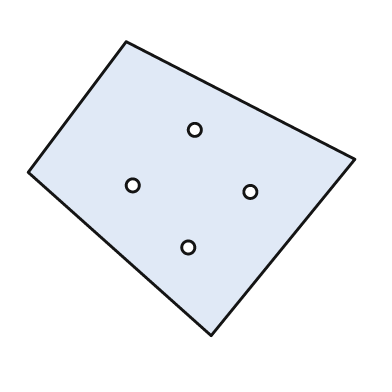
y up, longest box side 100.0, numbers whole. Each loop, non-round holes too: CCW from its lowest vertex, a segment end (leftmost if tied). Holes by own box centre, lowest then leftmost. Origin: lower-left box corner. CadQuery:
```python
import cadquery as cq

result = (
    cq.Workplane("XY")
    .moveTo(56.0, 0.0)
    .lineTo(100.0, 54.0)
    .lineTo(30.0, 90.0)
    .lineTo(0.0, 50.0)
    .close()
    .moveTo(49.0, 27.0)
    .circle(2.0)
    .moveTo(68.0, 44.0)
    .circle(2.0)
    .moveTo(32.0, 46.0)
    .circle(2.0)
    .moveTo(51.0, 63.0)
    .circle(2.0)
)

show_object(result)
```